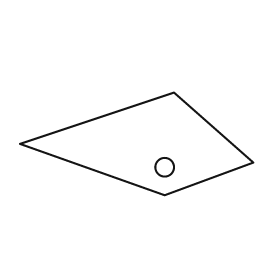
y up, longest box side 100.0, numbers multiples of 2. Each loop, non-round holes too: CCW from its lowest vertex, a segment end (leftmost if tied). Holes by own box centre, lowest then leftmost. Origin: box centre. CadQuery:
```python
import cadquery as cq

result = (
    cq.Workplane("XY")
    .moveTo(12.0, -22.0)
    .lineTo(50.0, -8.0)
    .lineTo(16.0, 22.0)
    .lineTo(-50.0, 0.0)
    .close()
    .moveTo(12.0, -10.0)
    .circle(4.0)
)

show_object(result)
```